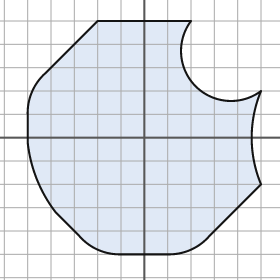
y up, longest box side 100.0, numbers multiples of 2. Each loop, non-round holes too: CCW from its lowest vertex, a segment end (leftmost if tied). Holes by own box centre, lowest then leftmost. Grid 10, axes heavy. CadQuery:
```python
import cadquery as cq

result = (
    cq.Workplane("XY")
    .moveTo(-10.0, -50.0)
    .lineTo(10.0, -50.0)
    .threePointArc((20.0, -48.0), (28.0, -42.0))
    .lineTo(50.0, -20.0)
    .threePointArc((46.0, 0.0), (50.0, 20.0))
    .threePointArc((22.0, 22.0), (20.0, 50.0))
    .lineTo(-20.0, 50.0)
    .lineTo(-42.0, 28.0)
    .threePointArc((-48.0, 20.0), (-50.0, 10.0))
    .lineTo(-50.0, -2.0)
    .threePointArc((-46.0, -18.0), (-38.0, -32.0))
    .lineTo(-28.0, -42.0)
    .threePointArc((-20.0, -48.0), (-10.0, -50.0))
    .close()
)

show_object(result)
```